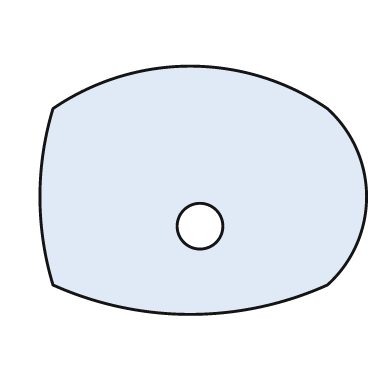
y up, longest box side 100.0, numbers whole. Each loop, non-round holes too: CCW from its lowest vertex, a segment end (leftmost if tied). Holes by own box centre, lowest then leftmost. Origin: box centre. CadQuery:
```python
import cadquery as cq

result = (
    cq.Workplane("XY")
    .moveTo(-46.0, -29.0)
    .threePointArc((-4.0, -38.0), (38.0, -29.0))
    .threePointArc((50.0, -2.0), (38.0, 25.0))
    .threePointArc((-4.0, 38.0), (-46.0, 25.0))
    .threePointArc((-50.0, -2.0), (-46.0, -29.0))
    .close()
    .moveTo(-1.0, -11.0)
    .circle(7.0)
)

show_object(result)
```